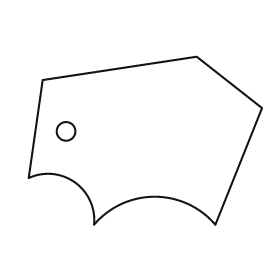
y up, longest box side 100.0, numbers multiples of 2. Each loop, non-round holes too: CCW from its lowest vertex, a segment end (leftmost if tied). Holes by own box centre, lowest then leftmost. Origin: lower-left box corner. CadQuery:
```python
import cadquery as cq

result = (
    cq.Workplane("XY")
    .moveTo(28.0, 0.0)
    .threePointArc((54.0, 12.0), (80.0, 0.0))
    .lineTo(100.0, 50.0)
    .lineTo(72.0, 72.0)
    .lineTo(6.0, 62.0)
    .lineTo(0.0, 20.0)
    .threePointArc((20.0, 18.0), (28.0, 0.0))
    .close()
    .moveTo(16.0, 40.0)
    .circle(4.0)
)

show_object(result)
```